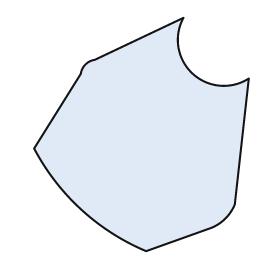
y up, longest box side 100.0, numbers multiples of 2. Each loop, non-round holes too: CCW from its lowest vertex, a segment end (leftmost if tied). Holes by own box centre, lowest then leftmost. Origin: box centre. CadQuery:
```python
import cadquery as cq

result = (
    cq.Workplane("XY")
    .moveTo(2.0, -50.0)
    .lineTo(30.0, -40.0)
    .threePointArc((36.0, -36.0), (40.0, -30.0))
    .lineTo(46.0, 24.0)
    .threePointArc((22.0, 26.0), (18.0, 50.0))
    .lineTo(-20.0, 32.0)
    .threePointArc((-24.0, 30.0), (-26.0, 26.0))
    .lineTo(-46.0, -6.0)
    .threePointArc((-26.0, -32.0), (2.0, -50.0))
    .close()
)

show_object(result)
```